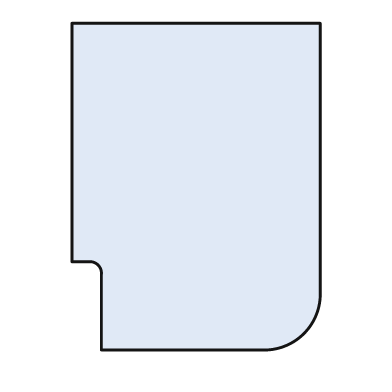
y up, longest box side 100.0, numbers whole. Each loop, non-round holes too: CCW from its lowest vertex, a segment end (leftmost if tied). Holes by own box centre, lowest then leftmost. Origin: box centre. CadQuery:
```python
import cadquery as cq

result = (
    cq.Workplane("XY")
    .moveTo(-29.0, -50.0)
    .lineTo(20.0, -50.0)
    .threePointArc((33.0, -45.0), (38.0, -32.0))
    .lineTo(38.0, 50.0)
    .lineTo(-38.0, 50.0)
    .lineTo(-38.0, -23.0)
    .lineTo(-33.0, -23.0)
    .threePointArc((-30.0, -24.0), (-29.0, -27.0))
    .close()
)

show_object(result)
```